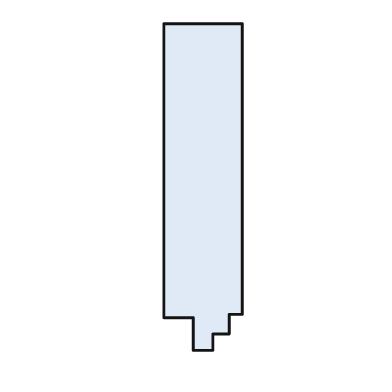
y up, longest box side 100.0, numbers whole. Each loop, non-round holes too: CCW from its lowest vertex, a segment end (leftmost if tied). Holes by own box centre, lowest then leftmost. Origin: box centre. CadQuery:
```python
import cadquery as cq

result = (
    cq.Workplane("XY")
    .moveTo(-3.0, -50.0)
    .lineTo(3.0, -50.0)
    .lineTo(3.0, -45.0)
    .lineTo(8.0, -45.0)
    .lineTo(8.0, -39.0)
    .lineTo(12.0, -39.0)
    .lineTo(12.0, 50.0)
    .lineTo(-12.0, 50.0)
    .lineTo(-12.0, -40.0)
    .lineTo(-3.0, -40.0)
    .close()
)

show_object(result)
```